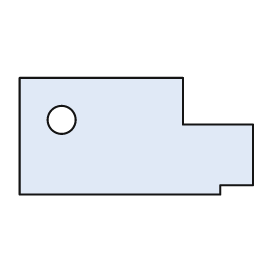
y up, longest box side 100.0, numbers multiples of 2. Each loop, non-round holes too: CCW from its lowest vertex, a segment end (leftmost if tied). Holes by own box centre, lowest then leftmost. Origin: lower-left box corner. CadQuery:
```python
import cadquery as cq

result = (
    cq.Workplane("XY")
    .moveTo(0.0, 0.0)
    .lineTo(86.0, 0.0)
    .lineTo(86.0, 4.0)
    .lineTo(100.0, 4.0)
    .lineTo(100.0, 30.0)
    .lineTo(70.0, 30.0)
    .lineTo(70.0, 50.0)
    .lineTo(0.0, 50.0)
    .close()
    .moveTo(18.0, 32.0)
    .circle(6.0)
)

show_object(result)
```